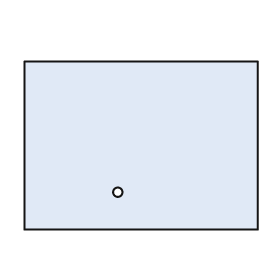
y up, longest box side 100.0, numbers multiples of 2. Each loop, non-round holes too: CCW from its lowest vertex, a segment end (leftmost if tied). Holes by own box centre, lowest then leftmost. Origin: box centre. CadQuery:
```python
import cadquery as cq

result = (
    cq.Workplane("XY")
    .moveTo(-50.0, -36.0)
    .lineTo(50.0, -36.0)
    .lineTo(50.0, 36.0)
    .lineTo(-50.0, 36.0)
    .close()
    .moveTo(-10.0, -20.0)
    .circle(2.0)
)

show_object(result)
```